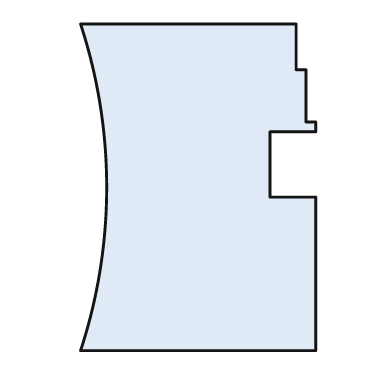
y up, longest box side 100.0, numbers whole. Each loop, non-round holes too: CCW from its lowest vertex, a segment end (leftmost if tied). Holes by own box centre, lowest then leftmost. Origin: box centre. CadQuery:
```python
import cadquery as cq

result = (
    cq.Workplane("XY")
    .moveTo(-36.0, -50.0)
    .lineTo(36.0, -50.0)
    .lineTo(36.0, -3.0)
    .lineTo(22.0, -3.0)
    .lineTo(22.0, 17.0)
    .lineTo(36.0, 17.0)
    .lineTo(36.0, 20.0)
    .lineTo(33.0, 20.0)
    .lineTo(33.0, 36.0)
    .lineTo(30.0, 36.0)
    .lineTo(30.0, 50.0)
    .lineTo(-36.0, 50.0)
    .threePointArc((-28.0, 0.0), (-36.0, -50.0))
    .close()
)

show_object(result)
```